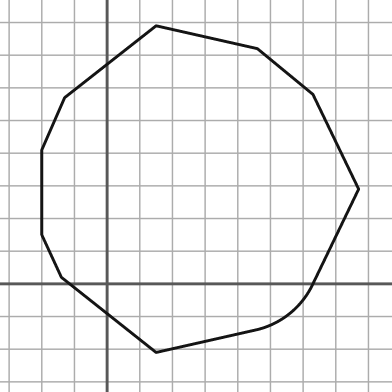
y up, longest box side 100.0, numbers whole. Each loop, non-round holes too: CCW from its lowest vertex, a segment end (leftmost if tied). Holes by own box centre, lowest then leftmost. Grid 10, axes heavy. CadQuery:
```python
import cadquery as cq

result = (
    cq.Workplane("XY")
    .moveTo(15.0, -21.0)
    .lineTo(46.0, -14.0)
    .threePointArc((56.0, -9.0), (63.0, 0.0))
    .lineTo(77.0, 29.0)
    .lineTo(63.0, 58.0)
    .lineTo(46.0, 72.0)
    .lineTo(15.0, 79.0)
    .lineTo(-13.0, 57.0)
    .lineTo(-20.0, 41.0)
    .lineTo(-20.0, 15.0)
    .lineTo(-14.0, 2.0)
    .close()
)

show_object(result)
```